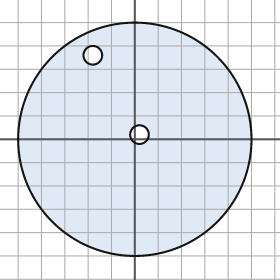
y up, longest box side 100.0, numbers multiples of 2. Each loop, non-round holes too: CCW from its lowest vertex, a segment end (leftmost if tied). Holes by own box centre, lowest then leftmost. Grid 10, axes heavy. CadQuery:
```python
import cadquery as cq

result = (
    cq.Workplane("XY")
    .moveTo(0.0, 0.0)
    .circle(50.0)
    .moveTo(2.0, 2.0)
    .circle(4.0)
    .moveTo(-18.0, 36.0)
    .circle(4.0)
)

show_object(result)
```